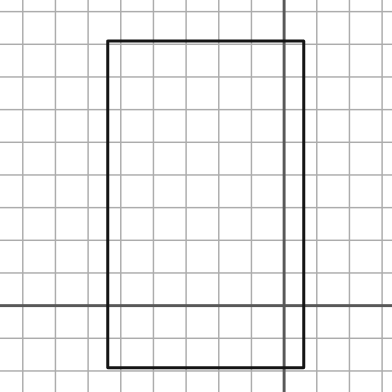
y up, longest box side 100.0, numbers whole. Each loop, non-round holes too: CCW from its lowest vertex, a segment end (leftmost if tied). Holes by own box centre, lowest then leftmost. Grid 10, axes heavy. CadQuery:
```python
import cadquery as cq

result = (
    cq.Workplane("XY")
    .moveTo(-54.0, -19.0)
    .lineTo(6.0, -19.0)
    .lineTo(6.0, 81.0)
    .lineTo(-54.0, 81.0)
    .close()
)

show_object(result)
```